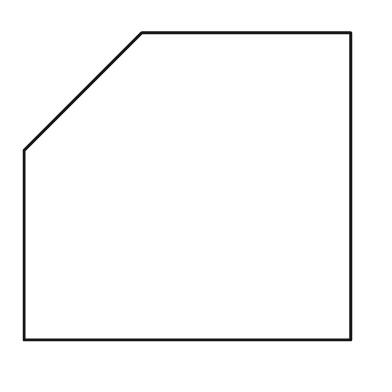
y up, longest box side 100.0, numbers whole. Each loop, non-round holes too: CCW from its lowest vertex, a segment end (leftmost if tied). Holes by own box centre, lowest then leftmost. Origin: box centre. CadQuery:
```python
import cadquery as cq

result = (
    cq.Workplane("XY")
    .moveTo(-50.0, -47.0)
    .lineTo(50.0, -47.0)
    .lineTo(50.0, 47.0)
    .lineTo(-14.0, 47.0)
    .lineTo(-50.0, 11.0)
    .close()
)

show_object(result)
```